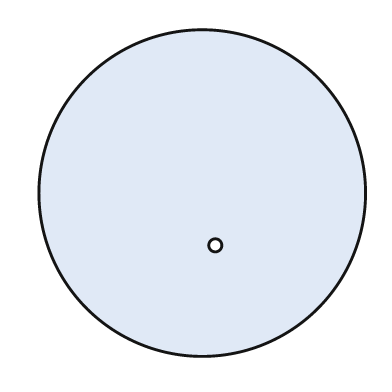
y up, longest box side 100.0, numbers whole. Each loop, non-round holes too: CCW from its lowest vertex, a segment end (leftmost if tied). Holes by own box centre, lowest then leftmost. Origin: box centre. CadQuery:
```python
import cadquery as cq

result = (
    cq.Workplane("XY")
    .moveTo(0.0, 0.0)
    .circle(50.0)
    .moveTo(4.0, -16.0)
    .circle(2.0)
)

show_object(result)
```